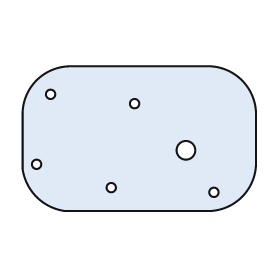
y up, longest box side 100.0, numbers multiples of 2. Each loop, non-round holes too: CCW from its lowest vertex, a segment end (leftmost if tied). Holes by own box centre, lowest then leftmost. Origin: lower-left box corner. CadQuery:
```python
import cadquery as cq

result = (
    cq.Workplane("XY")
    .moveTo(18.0, 0.0)
    .lineTo(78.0, 0.0)
    .threePointArc((94.0, 6.0), (100.0, 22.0))
    .lineTo(100.0, 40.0)
    .threePointArc((94.0, 56.0), (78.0, 62.0))
    .lineTo(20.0, 62.0)
    .threePointArc((6.0, 56.0), (0.0, 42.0))
    .lineTo(0.0, 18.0)
    .threePointArc((6.0, 6.0), (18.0, 0.0))
    .close()
    .moveTo(82.0, 8.0)
    .circle(2.0)
    .moveTo(38.0, 10.0)
    .circle(2.0)
    .moveTo(6.0, 20.0)
    .circle(2.0)
    .moveTo(70.0, 26.0)
    .circle(4.0)
    .moveTo(48.0, 46.0)
    .circle(2.0)
    .moveTo(12.0, 50.0)
    .circle(2.0)
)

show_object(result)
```